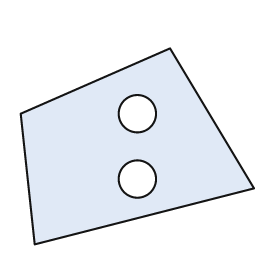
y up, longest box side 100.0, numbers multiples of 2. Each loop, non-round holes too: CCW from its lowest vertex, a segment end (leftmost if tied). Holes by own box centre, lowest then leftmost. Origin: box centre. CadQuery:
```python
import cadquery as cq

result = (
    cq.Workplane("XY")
    .moveTo(-44.0, -42.0)
    .lineTo(50.0, -18.0)
    .lineTo(14.0, 42.0)
    .lineTo(-50.0, 14.0)
    .close()
    .moveTo(0.0, -14.0)
    .circle(8.0)
    .moveTo(0.0, 14.0)
    .circle(8.0)
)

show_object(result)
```